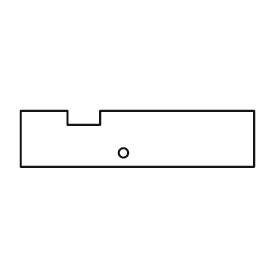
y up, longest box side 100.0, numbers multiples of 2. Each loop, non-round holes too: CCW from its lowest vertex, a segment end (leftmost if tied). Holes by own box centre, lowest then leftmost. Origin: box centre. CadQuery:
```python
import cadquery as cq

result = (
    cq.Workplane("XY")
    .moveTo(-50.0, -12.0)
    .lineTo(50.0, -12.0)
    .lineTo(50.0, 12.0)
    .lineTo(-16.0, 12.0)
    .lineTo(-16.0, 6.0)
    .lineTo(-30.0, 6.0)
    .lineTo(-30.0, 12.0)
    .lineTo(-50.0, 12.0)
    .close()
    .moveTo(-6.0, -6.0)
    .circle(2.0)
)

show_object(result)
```